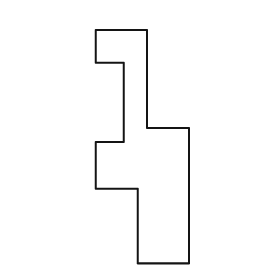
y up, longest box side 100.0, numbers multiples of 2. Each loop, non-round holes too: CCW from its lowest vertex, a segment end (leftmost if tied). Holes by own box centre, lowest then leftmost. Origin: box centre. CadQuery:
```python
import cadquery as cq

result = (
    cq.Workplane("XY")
    .moveTo(-2.0, -50.0)
    .lineTo(20.0, -50.0)
    .lineTo(20.0, 8.0)
    .lineTo(2.0, 8.0)
    .lineTo(2.0, 50.0)
    .lineTo(-20.0, 50.0)
    .lineTo(-20.0, 36.0)
    .lineTo(-8.0, 36.0)
    .lineTo(-8.0, 2.0)
    .lineTo(-20.0, 2.0)
    .lineTo(-20.0, -18.0)
    .lineTo(-2.0, -18.0)
    .close()
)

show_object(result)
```